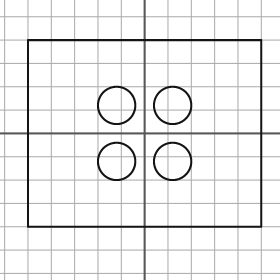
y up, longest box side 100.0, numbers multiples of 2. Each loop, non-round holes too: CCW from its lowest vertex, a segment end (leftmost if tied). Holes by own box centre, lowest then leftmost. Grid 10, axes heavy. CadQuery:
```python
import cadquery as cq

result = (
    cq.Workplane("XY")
    .moveTo(-50.0, -40.0)
    .lineTo(50.0, -40.0)
    .lineTo(50.0, 40.0)
    .lineTo(-50.0, 40.0)
    .close()
    .moveTo(-12.0, -12.0)
    .circle(8.0)
    .moveTo(12.0, -12.0)
    .circle(8.0)
    .moveTo(-12.0, 12.0)
    .circle(8.0)
    .moveTo(12.0, 12.0)
    .circle(8.0)
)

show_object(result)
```